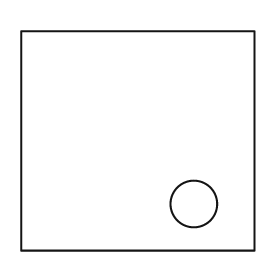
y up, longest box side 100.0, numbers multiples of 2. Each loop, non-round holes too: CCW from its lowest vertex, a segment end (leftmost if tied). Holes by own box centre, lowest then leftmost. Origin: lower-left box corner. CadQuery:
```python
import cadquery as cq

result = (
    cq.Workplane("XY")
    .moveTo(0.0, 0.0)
    .lineTo(100.0, 0.0)
    .lineTo(100.0, 94.0)
    .lineTo(0.0, 94.0)
    .close()
    .moveTo(74.0, 20.0)
    .circle(10.0)
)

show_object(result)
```